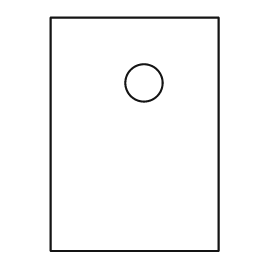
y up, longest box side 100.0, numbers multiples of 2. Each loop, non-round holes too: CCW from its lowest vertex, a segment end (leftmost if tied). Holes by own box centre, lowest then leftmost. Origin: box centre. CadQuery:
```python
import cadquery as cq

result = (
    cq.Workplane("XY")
    .moveTo(-36.0, -50.0)
    .lineTo(36.0, -50.0)
    .lineTo(36.0, 50.0)
    .lineTo(-36.0, 50.0)
    .close()
    .moveTo(4.0, 22.0)
    .circle(8.0)
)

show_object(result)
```